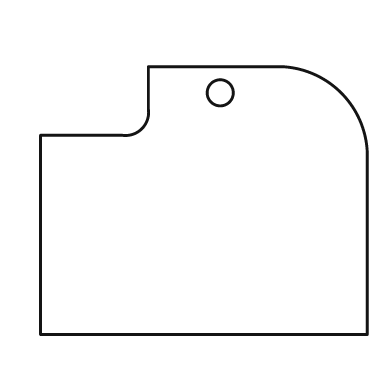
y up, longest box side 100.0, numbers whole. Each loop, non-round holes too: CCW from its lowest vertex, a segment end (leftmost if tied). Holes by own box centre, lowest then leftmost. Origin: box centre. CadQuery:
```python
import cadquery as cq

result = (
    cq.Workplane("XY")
    .moveTo(-50.0, -41.0)
    .lineTo(50.0, -41.0)
    .lineTo(50.0, 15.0)
    .threePointArc((42.0, 33.0), (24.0, 41.0))
    .lineTo(-17.0, 41.0)
    .lineTo(-17.0, 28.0)
    .threePointArc((-19.0, 22.0), (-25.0, 20.0))
    .lineTo(-50.0, 20.0)
    .close()
    .moveTo(5.0, 33.0)
    .circle(4.0)
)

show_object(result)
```